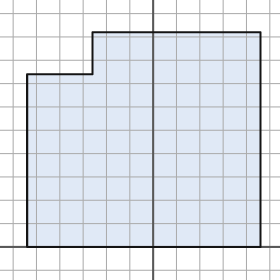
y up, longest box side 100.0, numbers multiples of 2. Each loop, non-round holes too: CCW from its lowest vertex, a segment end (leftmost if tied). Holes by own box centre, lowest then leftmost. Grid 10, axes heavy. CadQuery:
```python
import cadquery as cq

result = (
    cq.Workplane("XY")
    .moveTo(-54.0, 0.0)
    .lineTo(46.0, 0.0)
    .lineTo(46.0, 92.0)
    .lineTo(-26.0, 92.0)
    .lineTo(-26.0, 74.0)
    .lineTo(-54.0, 74.0)
    .close()
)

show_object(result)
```